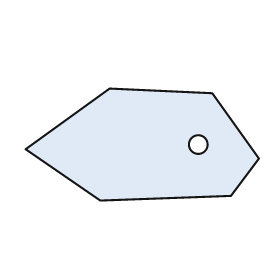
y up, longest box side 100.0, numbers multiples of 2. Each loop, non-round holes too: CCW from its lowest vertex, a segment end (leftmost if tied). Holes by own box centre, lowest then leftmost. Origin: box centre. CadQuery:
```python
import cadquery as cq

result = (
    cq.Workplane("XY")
    .moveTo(-18.0, -24.0)
    .lineTo(38.0, -22.0)
    .lineTo(50.0, -6.0)
    .lineTo(30.0, 22.0)
    .lineTo(-14.0, 24.0)
    .lineTo(-50.0, -2.0)
    .close()
    .moveTo(24.0, 0.0)
    .circle(4.0)
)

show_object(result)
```